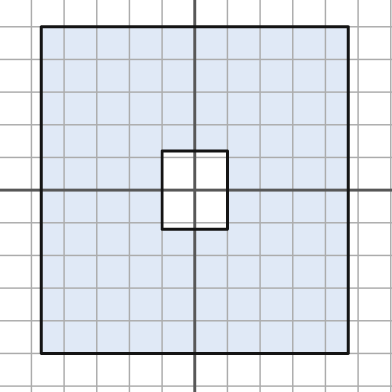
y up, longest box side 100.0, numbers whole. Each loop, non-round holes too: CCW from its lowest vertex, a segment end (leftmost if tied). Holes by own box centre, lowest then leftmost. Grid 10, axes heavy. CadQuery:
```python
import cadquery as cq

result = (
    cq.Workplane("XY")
    .moveTo(-47.0, -50.0)
    .lineTo(47.0, -50.0)
    .lineTo(47.0, 50.0)
    .lineTo(-47.0, 50.0)
    .close()
    .moveTo(-10.0, -12.0)
    .lineTo(10.0, -12.0)
    .lineTo(10.0, 12.0)
    .lineTo(-10.0, 12.0)
    .close()
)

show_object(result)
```